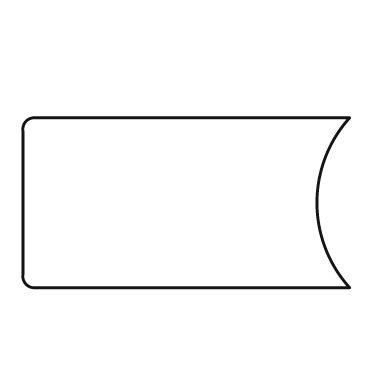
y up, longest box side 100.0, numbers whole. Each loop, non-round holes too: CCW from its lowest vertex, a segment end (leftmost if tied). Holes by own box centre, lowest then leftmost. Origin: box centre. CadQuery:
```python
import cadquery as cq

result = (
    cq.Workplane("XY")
    .moveTo(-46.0, -26.0)
    .lineTo(50.0, -26.0)
    .threePointArc((40.0, 0.0), (50.0, 26.0))
    .lineTo(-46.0, 26.0)
    .threePointArc((-49.0, 25.0), (-50.0, 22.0))
    .lineTo(-50.0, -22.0)
    .threePointArc((-49.0, -25.0), (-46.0, -26.0))
    .close()
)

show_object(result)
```